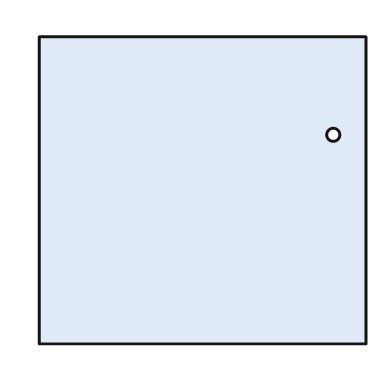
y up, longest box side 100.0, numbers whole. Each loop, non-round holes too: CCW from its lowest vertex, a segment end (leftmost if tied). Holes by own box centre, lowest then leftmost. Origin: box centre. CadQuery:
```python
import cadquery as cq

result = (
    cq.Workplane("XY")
    .moveTo(-50.0, -47.0)
    .lineTo(50.0, -47.0)
    .lineTo(50.0, 47.0)
    .lineTo(-50.0, 47.0)
    .close()
    .moveTo(40.0, 17.0)
    .circle(2.0)
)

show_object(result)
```